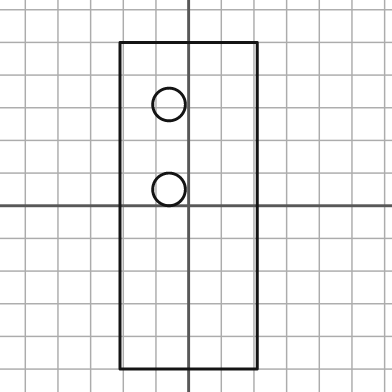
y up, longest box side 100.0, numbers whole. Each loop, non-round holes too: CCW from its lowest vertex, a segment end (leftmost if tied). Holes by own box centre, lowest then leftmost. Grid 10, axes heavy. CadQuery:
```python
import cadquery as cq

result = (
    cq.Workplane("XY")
    .moveTo(-21.0, -50.0)
    .lineTo(21.0, -50.0)
    .lineTo(21.0, 50.0)
    .lineTo(-21.0, 50.0)
    .close()
    .moveTo(-6.0, 5.0)
    .circle(5.0)
    .moveTo(-6.0, 31.0)
    .circle(5.0)
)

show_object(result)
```